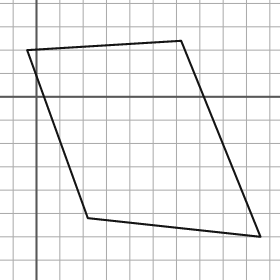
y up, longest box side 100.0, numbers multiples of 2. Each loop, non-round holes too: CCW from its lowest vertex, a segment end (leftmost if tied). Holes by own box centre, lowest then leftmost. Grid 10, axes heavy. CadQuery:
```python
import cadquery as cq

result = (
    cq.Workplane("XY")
    .moveTo(96.0, -60.0)
    .lineTo(62.0, 24.0)
    .lineTo(-4.0, 20.0)
    .lineTo(22.0, -52.0)
    .close()
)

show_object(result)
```